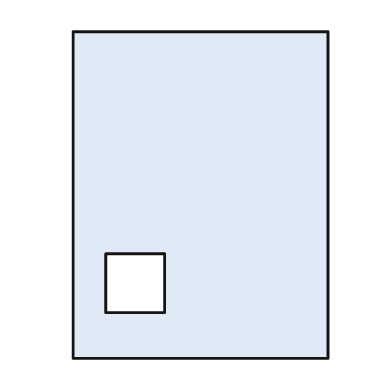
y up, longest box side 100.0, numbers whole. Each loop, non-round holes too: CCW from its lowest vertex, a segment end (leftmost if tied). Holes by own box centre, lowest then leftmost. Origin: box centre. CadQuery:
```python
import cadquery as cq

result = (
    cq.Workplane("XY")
    .moveTo(-39.0, -50.0)
    .lineTo(39.0, -50.0)
    .lineTo(39.0, 50.0)
    .lineTo(-39.0, 50.0)
    .close()
    .moveTo(-29.0, -36.0)
    .lineTo(-11.0, -36.0)
    .lineTo(-11.0, -18.0)
    .lineTo(-29.0, -18.0)
    .close()
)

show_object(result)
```